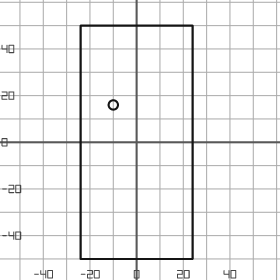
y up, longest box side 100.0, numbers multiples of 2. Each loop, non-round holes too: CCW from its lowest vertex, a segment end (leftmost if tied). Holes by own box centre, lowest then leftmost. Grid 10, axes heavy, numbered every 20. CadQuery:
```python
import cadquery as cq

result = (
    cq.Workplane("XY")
    .moveTo(-24.0, -50.0)
    .lineTo(24.0, -50.0)
    .lineTo(24.0, 50.0)
    .lineTo(-24.0, 50.0)
    .close()
    .moveTo(-10.0, 16.0)
    .circle(2.0)
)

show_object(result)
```